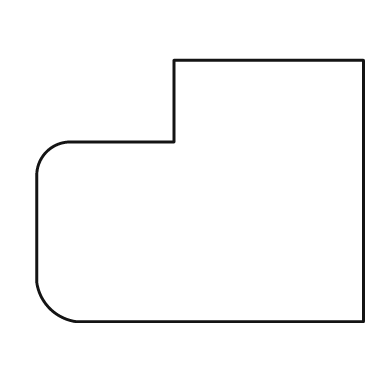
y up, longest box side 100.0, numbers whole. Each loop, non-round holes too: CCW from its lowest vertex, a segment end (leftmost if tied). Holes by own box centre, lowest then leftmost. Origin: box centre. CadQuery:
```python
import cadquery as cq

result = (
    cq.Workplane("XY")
    .moveTo(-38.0, -40.0)
    .lineTo(50.0, -40.0)
    .lineTo(50.0, 40.0)
    .lineTo(-8.0, 40.0)
    .lineTo(-8.0, 15.0)
    .lineTo(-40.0, 15.0)
    .threePointArc((-47.0, 12.0), (-50.0, 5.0))
    .lineTo(-50.0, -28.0)
    .threePointArc((-46.0, -36.0), (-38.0, -40.0))
    .close()
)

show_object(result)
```